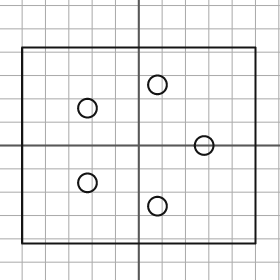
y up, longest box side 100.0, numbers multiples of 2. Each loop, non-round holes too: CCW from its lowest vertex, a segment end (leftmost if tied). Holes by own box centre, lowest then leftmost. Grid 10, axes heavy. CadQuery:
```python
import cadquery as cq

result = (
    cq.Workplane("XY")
    .moveTo(-50.0, -42.0)
    .lineTo(50.0, -42.0)
    .lineTo(50.0, 42.0)
    .lineTo(-50.0, 42.0)
    .close()
    .moveTo(8.0, -26.0)
    .circle(4.0)
    .moveTo(-22.0, -16.0)
    .circle(4.0)
    .moveTo(28.0, 0.0)
    .circle(4.0)
    .moveTo(-22.0, 16.0)
    .circle(4.0)
    .moveTo(8.0, 26.0)
    .circle(4.0)
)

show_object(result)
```